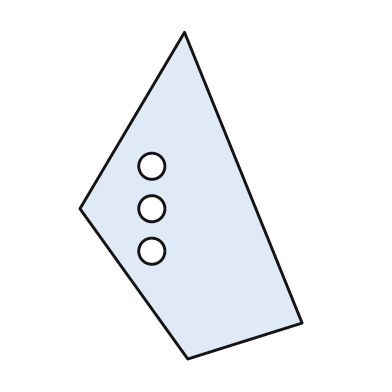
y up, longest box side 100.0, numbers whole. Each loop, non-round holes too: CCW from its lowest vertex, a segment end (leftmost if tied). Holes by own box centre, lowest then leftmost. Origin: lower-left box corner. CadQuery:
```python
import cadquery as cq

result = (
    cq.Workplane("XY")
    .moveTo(33.0, 0.0)
    .lineTo(68.0, 11.0)
    .lineTo(32.0, 100.0)
    .lineTo(0.0, 46.0)
    .close()
    .moveTo(22.0, 33.0)
    .circle(4.0)
    .moveTo(22.0, 46.0)
    .circle(4.0)
    .moveTo(22.0, 59.0)
    .circle(4.0)
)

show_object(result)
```